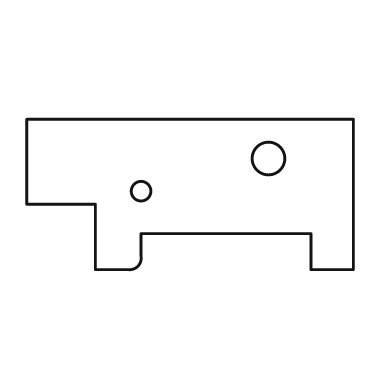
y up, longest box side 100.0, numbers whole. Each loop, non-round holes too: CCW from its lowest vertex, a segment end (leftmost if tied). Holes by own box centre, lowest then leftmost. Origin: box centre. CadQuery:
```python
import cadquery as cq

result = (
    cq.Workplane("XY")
    .moveTo(-29.0, -23.0)
    .lineTo(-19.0, -23.0)
    .threePointArc((-16.0, -22.0), (-15.0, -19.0))
    .lineTo(-15.0, -12.0)
    .lineTo(37.0, -12.0)
    .lineTo(37.0, -23.0)
    .lineTo(50.0, -23.0)
    .lineTo(50.0, 23.0)
    .lineTo(-50.0, 23.0)
    .lineTo(-50.0, -3.0)
    .lineTo(-29.0, -3.0)
    .close()
    .moveTo(-15.0, 1.0)
    .circle(3.0)
    .moveTo(24.0, 11.0)
    .circle(5.0)
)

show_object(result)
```